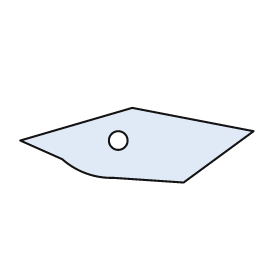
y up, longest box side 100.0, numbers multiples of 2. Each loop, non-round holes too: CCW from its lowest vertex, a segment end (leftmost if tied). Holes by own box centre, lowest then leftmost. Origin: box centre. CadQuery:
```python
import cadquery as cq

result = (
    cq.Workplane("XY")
    .moveTo(20.0, -16.0)
    .lineTo(50.0, 6.0)
    .lineTo(-2.0, 16.0)
    .lineTo(-50.0, 2.0)
    .lineTo(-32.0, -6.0)
    .threePointArc((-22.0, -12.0), (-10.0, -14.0))
    .close()
    .moveTo(-8.0, 2.0)
    .circle(4.0)
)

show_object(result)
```